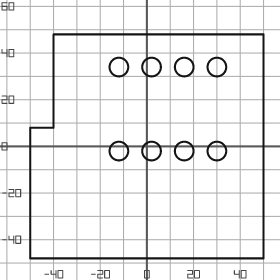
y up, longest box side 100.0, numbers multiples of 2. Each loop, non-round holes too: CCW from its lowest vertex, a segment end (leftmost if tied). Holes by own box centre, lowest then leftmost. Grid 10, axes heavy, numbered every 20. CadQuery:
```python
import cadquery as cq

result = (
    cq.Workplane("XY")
    .moveTo(-50.0, -48.0)
    .lineTo(50.0, -48.0)
    .lineTo(50.0, 48.0)
    .lineTo(-40.0, 48.0)
    .lineTo(-40.0, 8.0)
    .lineTo(-50.0, 8.0)
    .close()
    .moveTo(-12.0, -2.0)
    .circle(4.0)
    .moveTo(2.0, -2.0)
    .circle(4.0)
    .moveTo(16.0, -2.0)
    .circle(4.0)
    .moveTo(30.0, -2.0)
    .circle(4.0)
    .moveTo(-12.0, 34.0)
    .circle(4.0)
    .moveTo(2.0, 34.0)
    .circle(4.0)
    .moveTo(16.0, 34.0)
    .circle(4.0)
    .moveTo(30.0, 34.0)
    .circle(4.0)
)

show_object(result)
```